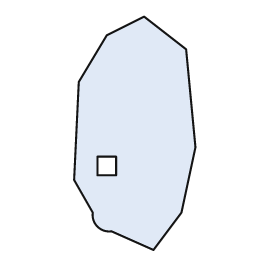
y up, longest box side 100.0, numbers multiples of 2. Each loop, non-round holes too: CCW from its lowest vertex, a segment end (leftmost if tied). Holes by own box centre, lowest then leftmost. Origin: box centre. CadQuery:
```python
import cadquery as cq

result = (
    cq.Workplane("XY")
    .moveTo(8.0, -50.0)
    .lineTo(20.0, -34.0)
    .lineTo(26.0, -6.0)
    .lineTo(22.0, 36.0)
    .lineTo(4.0, 50.0)
    .lineTo(-12.0, 42.0)
    .lineTo(-24.0, 22.0)
    .lineTo(-26.0, -20.0)
    .lineTo(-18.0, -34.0)
    .threePointArc((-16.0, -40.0), (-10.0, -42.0))
    .close()
    .moveTo(-16.0, -18.0)
    .lineTo(-8.0, -18.0)
    .lineTo(-8.0, -10.0)
    .lineTo(-16.0, -10.0)
    .close()
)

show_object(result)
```